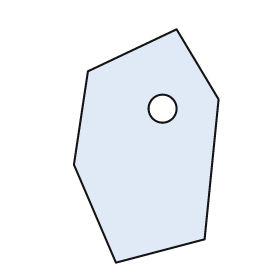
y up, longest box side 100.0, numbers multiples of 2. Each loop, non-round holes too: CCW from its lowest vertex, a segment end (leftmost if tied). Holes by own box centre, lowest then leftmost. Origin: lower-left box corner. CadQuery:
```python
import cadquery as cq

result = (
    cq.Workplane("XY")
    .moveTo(18.0, 0.0)
    .lineTo(56.0, 10.0)
    .lineTo(62.0, 70.0)
    .lineTo(44.0, 100.0)
    .lineTo(6.0, 82.0)
    .lineTo(0.0, 42.0)
    .close()
    .moveTo(38.0, 66.0)
    .circle(6.0)
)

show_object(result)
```